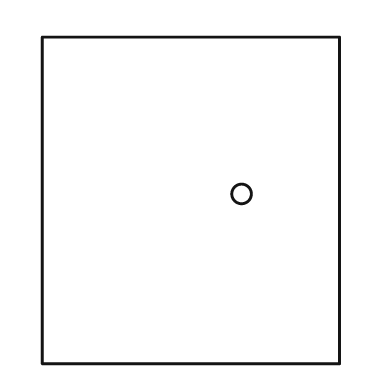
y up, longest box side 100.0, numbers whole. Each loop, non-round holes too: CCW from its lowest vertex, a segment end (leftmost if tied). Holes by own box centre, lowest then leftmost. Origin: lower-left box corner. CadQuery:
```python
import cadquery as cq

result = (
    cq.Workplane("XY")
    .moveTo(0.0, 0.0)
    .lineTo(91.0, 0.0)
    .lineTo(91.0, 100.0)
    .lineTo(0.0, 100.0)
    .close()
    .moveTo(61.0, 52.0)
    .circle(3.0)
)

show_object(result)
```